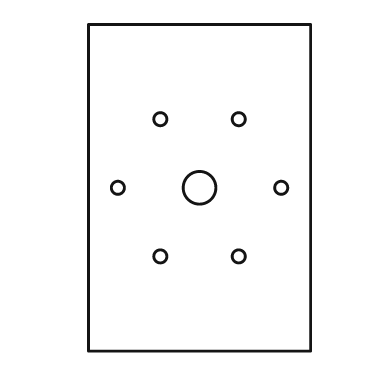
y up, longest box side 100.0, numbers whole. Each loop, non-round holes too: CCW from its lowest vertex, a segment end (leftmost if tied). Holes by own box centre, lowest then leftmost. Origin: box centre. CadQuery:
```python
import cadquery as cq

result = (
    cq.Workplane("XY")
    .moveTo(-34.0, -50.0)
    .lineTo(34.0, -50.0)
    .lineTo(34.0, 50.0)
    .lineTo(-34.0, 50.0)
    .close()
    .moveTo(-12.0, -21.0)
    .circle(2.0)
    .moveTo(12.0, -21.0)
    .circle(2.0)
    .moveTo(-25.0, 0.0)
    .circle(2.0)
    .moveTo(0.0, 0.0)
    .circle(5.0)
    .moveTo(25.0, 0.0)
    .circle(2.0)
    .moveTo(-12.0, 21.0)
    .circle(2.0)
    .moveTo(12.0, 21.0)
    .circle(2.0)
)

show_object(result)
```